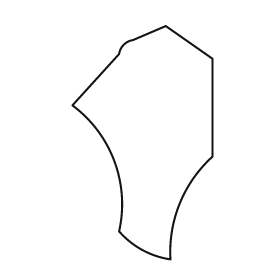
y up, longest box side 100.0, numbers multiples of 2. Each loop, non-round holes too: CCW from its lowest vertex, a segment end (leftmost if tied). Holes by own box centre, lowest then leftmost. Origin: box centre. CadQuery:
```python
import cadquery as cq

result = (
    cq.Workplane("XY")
    .moveTo(12.0, -50.0)
    .threePointArc((16.0, -26.0), (30.0, -6.0))
    .lineTo(30.0, 36.0)
    .lineTo(10.0, 50.0)
    .lineTo(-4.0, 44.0)
    .threePointArc((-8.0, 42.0), (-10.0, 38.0))
    .lineTo(-30.0, 16.0)
    .threePointArc((-12.0, -8.0), (-10.0, -38.0))
    .threePointArc((0.0, -46.0), (12.0, -50.0))
    .close()
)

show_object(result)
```